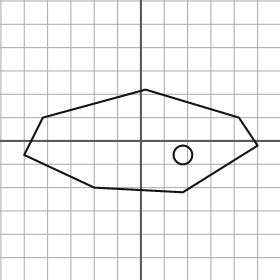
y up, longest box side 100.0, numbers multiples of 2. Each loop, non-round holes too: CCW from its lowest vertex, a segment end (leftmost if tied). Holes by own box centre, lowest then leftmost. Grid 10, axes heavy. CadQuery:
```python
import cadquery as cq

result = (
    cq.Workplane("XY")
    .moveTo(18.0, -22.0)
    .lineTo(50.0, -2.0)
    .lineTo(42.0, 10.0)
    .lineTo(2.0, 22.0)
    .lineTo(-42.0, 10.0)
    .lineTo(-50.0, -6.0)
    .lineTo(-20.0, -20.0)
    .close()
    .moveTo(18.0, -6.0)
    .circle(4.0)
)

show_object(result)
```